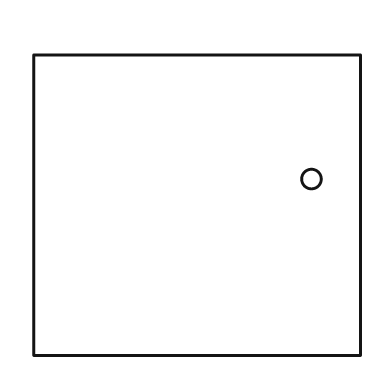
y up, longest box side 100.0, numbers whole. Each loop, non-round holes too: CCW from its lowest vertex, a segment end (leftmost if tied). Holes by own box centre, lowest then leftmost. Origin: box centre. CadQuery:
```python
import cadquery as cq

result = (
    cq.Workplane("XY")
    .moveTo(-50.0, -46.0)
    .lineTo(50.0, -46.0)
    .lineTo(50.0, 46.0)
    .lineTo(-50.0, 46.0)
    .close()
    .moveTo(35.0, 8.0)
    .circle(3.0)
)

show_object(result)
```